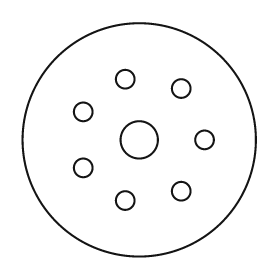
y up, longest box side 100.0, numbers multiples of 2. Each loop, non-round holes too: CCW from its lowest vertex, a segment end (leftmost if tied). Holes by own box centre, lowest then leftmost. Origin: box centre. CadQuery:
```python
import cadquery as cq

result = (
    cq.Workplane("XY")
    .moveTo(0.0, 0.0)
    .circle(50.0)
    .moveTo(-6.0, -26.0)
    .circle(4.0)
    .moveTo(18.0, -22.0)
    .circle(4.0)
    .moveTo(-24.0, -12.0)
    .circle(4.0)
    .moveTo(0.0, 0.0)
    .circle(8.0)
    .moveTo(28.0, 0.0)
    .circle(4.0)
    .moveTo(-24.0, 12.0)
    .circle(4.0)
    .moveTo(18.0, 22.0)
    .circle(4.0)
    .moveTo(-6.0, 26.0)
    .circle(4.0)
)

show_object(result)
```